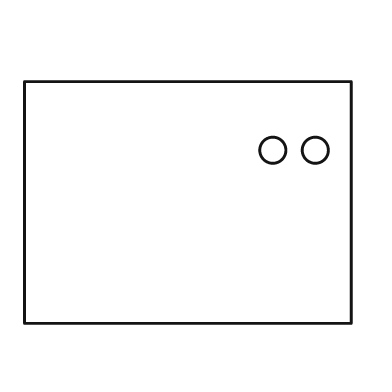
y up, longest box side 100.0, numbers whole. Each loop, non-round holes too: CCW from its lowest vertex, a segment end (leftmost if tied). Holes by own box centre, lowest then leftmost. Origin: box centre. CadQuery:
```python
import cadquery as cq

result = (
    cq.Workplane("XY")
    .moveTo(-50.0, -37.0)
    .lineTo(50.0, -37.0)
    .lineTo(50.0, 37.0)
    .lineTo(-50.0, 37.0)
    .close()
    .moveTo(26.0, 16.0)
    .circle(4.0)
    .moveTo(39.0, 16.0)
    .circle(4.0)
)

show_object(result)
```